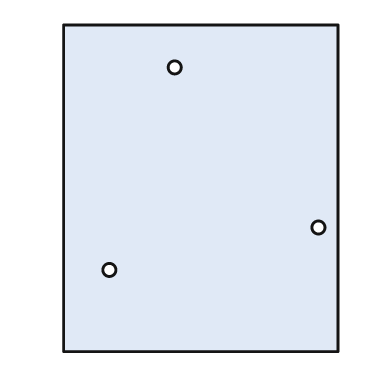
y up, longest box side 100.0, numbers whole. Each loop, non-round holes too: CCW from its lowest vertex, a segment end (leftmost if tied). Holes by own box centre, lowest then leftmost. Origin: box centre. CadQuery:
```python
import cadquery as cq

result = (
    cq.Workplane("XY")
    .moveTo(-42.0, -50.0)
    .lineTo(42.0, -50.0)
    .lineTo(42.0, 50.0)
    .lineTo(-42.0, 50.0)
    .close()
    .moveTo(-28.0, -25.0)
    .circle(2.0)
    .moveTo(36.0, -12.0)
    .circle(2.0)
    .moveTo(-8.0, 37.0)
    .circle(2.0)
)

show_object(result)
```